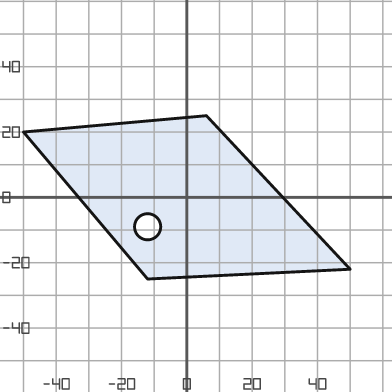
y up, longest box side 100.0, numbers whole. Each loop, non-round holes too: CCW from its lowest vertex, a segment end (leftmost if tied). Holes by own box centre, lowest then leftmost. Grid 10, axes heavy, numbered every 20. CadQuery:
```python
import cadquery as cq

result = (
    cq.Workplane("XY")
    .moveTo(-12.0, -25.0)
    .lineTo(50.0, -22.0)
    .lineTo(6.0, 25.0)
    .lineTo(-50.0, 20.0)
    .close()
    .moveTo(-12.0, -9.0)
    .circle(4.0)
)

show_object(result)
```